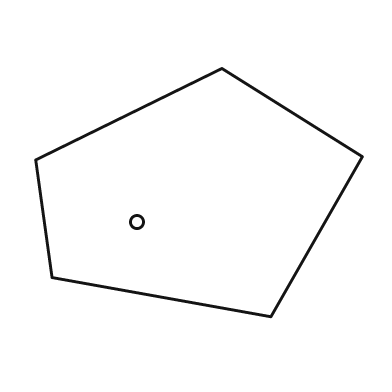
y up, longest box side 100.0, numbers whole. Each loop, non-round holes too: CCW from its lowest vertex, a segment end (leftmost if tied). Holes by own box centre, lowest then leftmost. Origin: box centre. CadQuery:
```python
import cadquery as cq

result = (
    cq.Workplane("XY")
    .moveTo(22.0, -38.0)
    .lineTo(50.0, 11.0)
    .lineTo(7.0, 38.0)
    .lineTo(-50.0, 10.0)
    .lineTo(-45.0, -26.0)
    .close()
    .moveTo(-19.0, -9.0)
    .circle(2.0)
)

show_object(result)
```